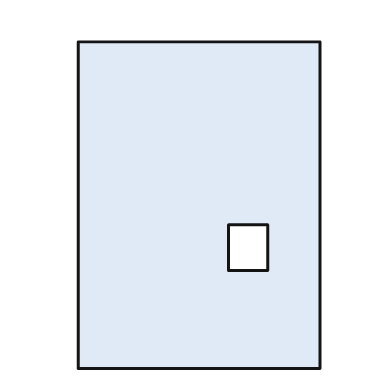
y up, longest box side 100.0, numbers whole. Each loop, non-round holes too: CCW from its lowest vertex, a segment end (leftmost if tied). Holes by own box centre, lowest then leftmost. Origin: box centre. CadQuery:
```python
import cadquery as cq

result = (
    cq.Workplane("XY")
    .moveTo(-37.0, -50.0)
    .lineTo(37.0, -50.0)
    .lineTo(37.0, 50.0)
    .lineTo(-37.0, 50.0)
    .close()
    .moveTo(9.0, -20.0)
    .lineTo(21.0, -20.0)
    .lineTo(21.0, -6.0)
    .lineTo(9.0, -6.0)
    .close()
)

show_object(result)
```